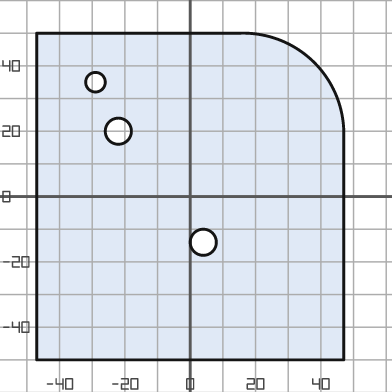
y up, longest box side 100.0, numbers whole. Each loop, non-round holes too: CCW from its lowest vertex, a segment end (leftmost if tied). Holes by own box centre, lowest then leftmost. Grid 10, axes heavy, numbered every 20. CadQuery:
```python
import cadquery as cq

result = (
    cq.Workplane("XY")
    .moveTo(-47.0, -50.0)
    .lineTo(47.0, -50.0)
    .lineTo(47.0, 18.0)
    .threePointArc((38.0, 41.0), (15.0, 50.0))
    .lineTo(-47.0, 50.0)
    .close()
    .moveTo(4.0, -14.0)
    .circle(4.0)
    .moveTo(-22.0, 20.0)
    .circle(4.0)
    .moveTo(-29.0, 35.0)
    .circle(3.0)
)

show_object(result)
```